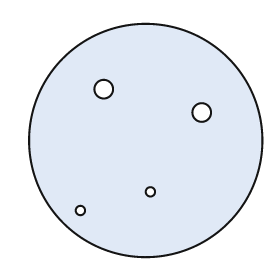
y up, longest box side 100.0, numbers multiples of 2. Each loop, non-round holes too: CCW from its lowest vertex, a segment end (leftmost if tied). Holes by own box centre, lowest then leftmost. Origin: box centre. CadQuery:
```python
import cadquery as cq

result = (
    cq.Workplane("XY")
    .moveTo(0.0, 0.0)
    .circle(50.0)
    .moveTo(-28.0, -30.0)
    .circle(2.0)
    .moveTo(2.0, -22.0)
    .circle(2.0)
    .moveTo(24.0, 12.0)
    .circle(4.0)
    .moveTo(-18.0, 22.0)
    .circle(4.0)
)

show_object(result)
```